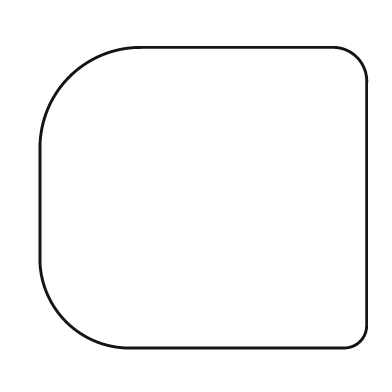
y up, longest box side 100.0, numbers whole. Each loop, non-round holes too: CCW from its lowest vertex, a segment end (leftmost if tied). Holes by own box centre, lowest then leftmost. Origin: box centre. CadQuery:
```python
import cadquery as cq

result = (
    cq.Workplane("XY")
    .moveTo(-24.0, -46.0)
    .lineTo(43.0, -46.0)
    .threePointArc((48.0, -44.0), (50.0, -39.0))
    .lineTo(50.0, 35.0)
    .threePointArc((47.0, 43.0), (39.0, 46.0))
    .lineTo(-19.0, 46.0)
    .threePointArc((-41.0, 37.0), (-50.0, 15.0))
    .lineTo(-50.0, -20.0)
    .threePointArc((-42.0, -38.0), (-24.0, -46.0))
    .close()
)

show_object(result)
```